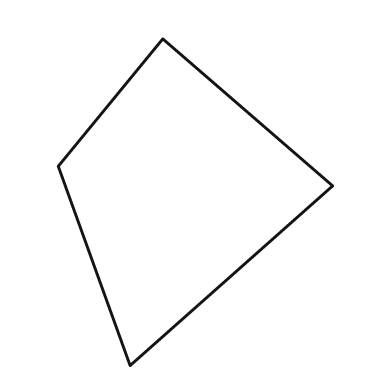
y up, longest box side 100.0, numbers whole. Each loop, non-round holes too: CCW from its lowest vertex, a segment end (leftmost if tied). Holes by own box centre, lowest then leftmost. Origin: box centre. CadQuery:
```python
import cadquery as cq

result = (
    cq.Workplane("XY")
    .moveTo(-20.0, -50.0)
    .lineTo(42.0, 5.0)
    .lineTo(-10.0, 50.0)
    .lineTo(-42.0, 11.0)
    .close()
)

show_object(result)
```